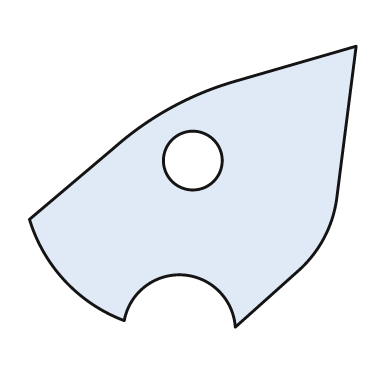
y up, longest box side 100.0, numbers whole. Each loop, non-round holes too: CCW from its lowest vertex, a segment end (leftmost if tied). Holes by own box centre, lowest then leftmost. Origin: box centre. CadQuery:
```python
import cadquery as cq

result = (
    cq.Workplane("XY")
    .moveTo(13.0, -43.0)
    .lineTo(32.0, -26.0)
    .threePointArc((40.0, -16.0), (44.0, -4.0))
    .lineTo(50.0, 43.0)
    .lineTo(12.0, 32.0)
    .threePointArc((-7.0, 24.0), (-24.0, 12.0))
    .lineTo(-50.0, -10.0)
    .threePointArc((-39.0, -29.0), (-21.0, -41.0))
    .threePointArc((-3.0, -27.0), (13.0, -43.0))
    .close()
    .moveTo(0.0, 8.0)
    .circle(9.0)
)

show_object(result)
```